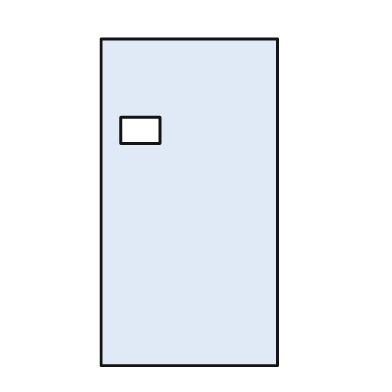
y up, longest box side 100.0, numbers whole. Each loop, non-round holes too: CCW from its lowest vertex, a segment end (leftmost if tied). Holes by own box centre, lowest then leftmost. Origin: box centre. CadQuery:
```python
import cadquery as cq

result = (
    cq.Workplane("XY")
    .moveTo(-27.0, -50.0)
    .lineTo(27.0, -50.0)
    .lineTo(27.0, 50.0)
    .lineTo(-27.0, 50.0)
    .close()
    .moveTo(-21.0, 18.0)
    .lineTo(-9.0, 18.0)
    .lineTo(-9.0, 26.0)
    .lineTo(-21.0, 26.0)
    .close()
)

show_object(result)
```